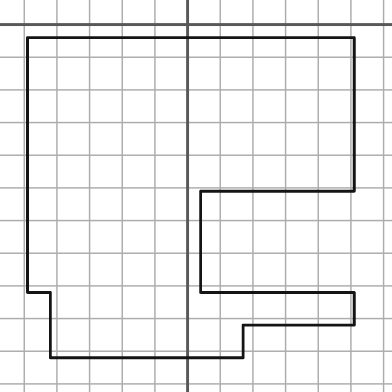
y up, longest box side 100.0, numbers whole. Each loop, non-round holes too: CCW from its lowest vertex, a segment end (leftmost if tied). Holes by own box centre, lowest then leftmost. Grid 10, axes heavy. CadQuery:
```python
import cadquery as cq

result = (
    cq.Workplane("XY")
    .moveTo(-42.0, -102.0)
    .lineTo(17.0, -102.0)
    .lineTo(17.0, -92.0)
    .lineTo(51.0, -92.0)
    .lineTo(51.0, -82.0)
    .lineTo(4.0, -82.0)
    .lineTo(4.0, -51.0)
    .lineTo(51.0, -51.0)
    .lineTo(51.0, -4.0)
    .lineTo(-49.0, -4.0)
    .lineTo(-49.0, -82.0)
    .lineTo(-42.0, -82.0)
    .close()
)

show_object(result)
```